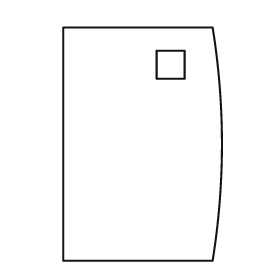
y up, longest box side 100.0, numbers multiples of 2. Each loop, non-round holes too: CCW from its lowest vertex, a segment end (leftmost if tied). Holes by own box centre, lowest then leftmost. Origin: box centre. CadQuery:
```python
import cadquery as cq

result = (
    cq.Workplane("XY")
    .moveTo(-34.0, -50.0)
    .lineTo(30.0, -50.0)
    .threePointArc((34.0, 0.0), (30.0, 50.0))
    .lineTo(-34.0, 50.0)
    .close()
    .moveTo(6.0, 28.0)
    .lineTo(18.0, 28.0)
    .lineTo(18.0, 40.0)
    .lineTo(6.0, 40.0)
    .close()
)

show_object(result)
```